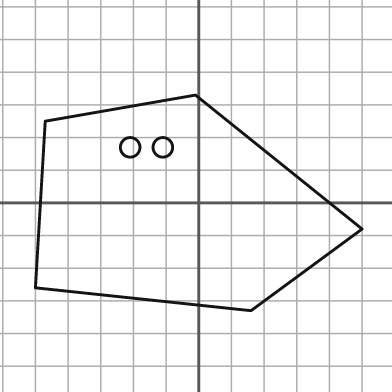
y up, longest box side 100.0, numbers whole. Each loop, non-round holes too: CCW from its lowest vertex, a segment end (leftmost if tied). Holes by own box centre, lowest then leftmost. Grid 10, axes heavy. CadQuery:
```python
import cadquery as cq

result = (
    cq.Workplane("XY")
    .moveTo(16.0, -33.0)
    .lineTo(50.0, -8.0)
    .lineTo(-1.0, 33.0)
    .lineTo(-47.0, 25.0)
    .lineTo(-50.0, -26.0)
    .close()
    .moveTo(-21.0, 17.0)
    .circle(3.0)
    .moveTo(-11.0, 17.0)
    .circle(3.0)
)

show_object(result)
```